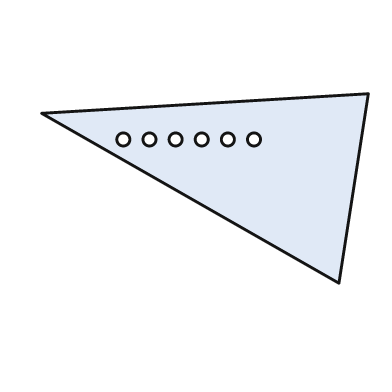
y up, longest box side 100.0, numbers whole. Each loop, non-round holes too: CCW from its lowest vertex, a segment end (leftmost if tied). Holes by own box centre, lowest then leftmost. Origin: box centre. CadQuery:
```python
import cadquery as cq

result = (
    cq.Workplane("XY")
    .moveTo(41.0, -29.0)
    .lineTo(50.0, 29.0)
    .lineTo(-50.0, 23.0)
    .close()
    .moveTo(-25.0, 15.0)
    .circle(2.0)
    .moveTo(-17.0, 15.0)
    .circle(2.0)
    .moveTo(-9.0, 15.0)
    .circle(2.0)
    .moveTo(-1.0, 15.0)
    .circle(2.0)
    .moveTo(7.0, 15.0)
    .circle(2.0)
    .moveTo(15.0, 15.0)
    .circle(2.0)
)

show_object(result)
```